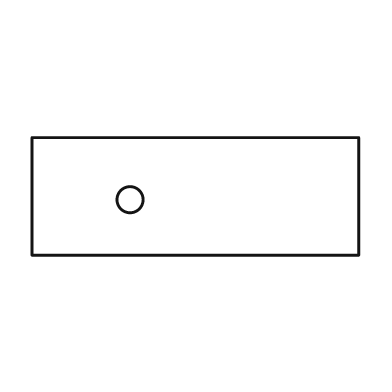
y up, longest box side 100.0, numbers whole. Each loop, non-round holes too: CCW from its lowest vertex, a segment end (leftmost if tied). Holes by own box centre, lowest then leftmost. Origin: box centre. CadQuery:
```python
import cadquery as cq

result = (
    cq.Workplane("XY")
    .moveTo(-50.0, -18.0)
    .lineTo(50.0, -18.0)
    .lineTo(50.0, 18.0)
    .lineTo(-50.0, 18.0)
    .close()
    .moveTo(-20.0, -1.0)
    .circle(4.0)
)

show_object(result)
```